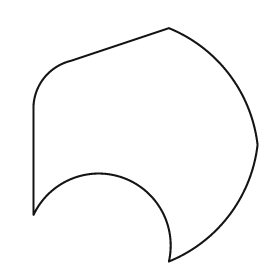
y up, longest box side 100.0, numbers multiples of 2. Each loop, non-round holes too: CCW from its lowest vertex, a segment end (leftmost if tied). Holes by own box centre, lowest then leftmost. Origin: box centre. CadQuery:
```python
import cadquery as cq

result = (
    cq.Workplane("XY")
    .moveTo(10.0, -50.0)
    .threePointArc((36.0, -30.0), (48.0, 0.0))
    .threePointArc((36.0, 30.0), (10.0, 50.0))
    .lineTo(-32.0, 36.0)
    .threePointArc((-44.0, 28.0), (-48.0, 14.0))
    .lineTo(-48.0, -30.0)
    .threePointArc((-10.0, -14.0), (10.0, -50.0))
    .close()
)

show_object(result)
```